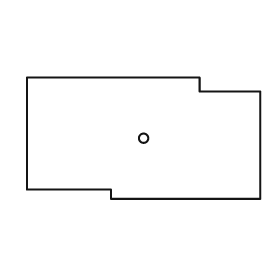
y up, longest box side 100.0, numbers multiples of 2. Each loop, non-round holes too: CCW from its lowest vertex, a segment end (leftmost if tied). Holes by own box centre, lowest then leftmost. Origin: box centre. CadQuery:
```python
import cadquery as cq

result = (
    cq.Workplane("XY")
    .moveTo(-14.0, -26.0)
    .lineTo(50.0, -26.0)
    .lineTo(50.0, 20.0)
    .lineTo(24.0, 20.0)
    .lineTo(24.0, 26.0)
    .lineTo(-50.0, 26.0)
    .lineTo(-50.0, -22.0)
    .lineTo(-14.0, -22.0)
    .close()
    .moveTo(0.0, 0.0)
    .circle(2.0)
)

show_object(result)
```